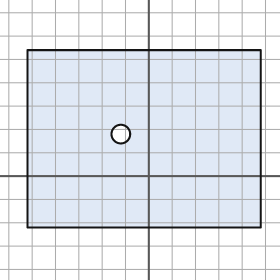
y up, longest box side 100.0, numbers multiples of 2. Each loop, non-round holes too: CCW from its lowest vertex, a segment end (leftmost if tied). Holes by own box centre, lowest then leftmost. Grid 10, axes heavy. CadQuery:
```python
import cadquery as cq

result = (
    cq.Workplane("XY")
    .moveTo(-52.0, -22.0)
    .lineTo(48.0, -22.0)
    .lineTo(48.0, 54.0)
    .lineTo(-52.0, 54.0)
    .close()
    .moveTo(-12.0, 18.0)
    .circle(4.0)
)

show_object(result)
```